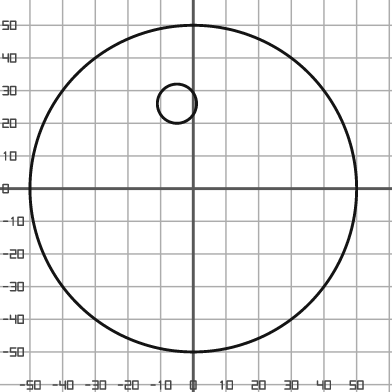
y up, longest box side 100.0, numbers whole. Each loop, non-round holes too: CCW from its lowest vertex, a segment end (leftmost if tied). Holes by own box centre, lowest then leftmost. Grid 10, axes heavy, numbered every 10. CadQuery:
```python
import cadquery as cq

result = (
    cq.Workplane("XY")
    .moveTo(0.0, 0.0)
    .circle(50.0)
    .moveTo(-5.0, 26.0)
    .circle(6.0)
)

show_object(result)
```